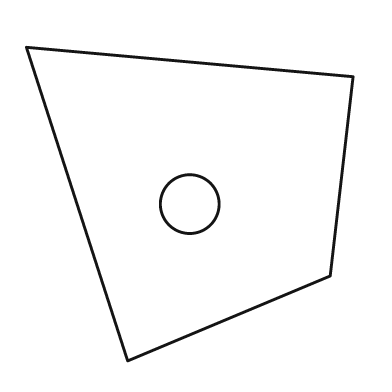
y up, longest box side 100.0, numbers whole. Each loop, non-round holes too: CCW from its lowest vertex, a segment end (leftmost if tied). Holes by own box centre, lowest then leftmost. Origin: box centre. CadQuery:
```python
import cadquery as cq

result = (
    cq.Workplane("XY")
    .moveTo(-19.0, -48.0)
    .lineTo(43.0, -22.0)
    .lineTo(50.0, 39.0)
    .lineTo(-50.0, 48.0)
    .close()
    .moveTo(0.0, 0.0)
    .circle(9.0)
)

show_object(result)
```